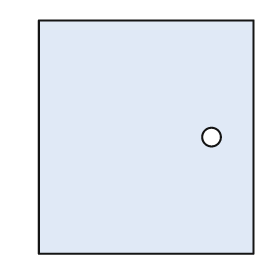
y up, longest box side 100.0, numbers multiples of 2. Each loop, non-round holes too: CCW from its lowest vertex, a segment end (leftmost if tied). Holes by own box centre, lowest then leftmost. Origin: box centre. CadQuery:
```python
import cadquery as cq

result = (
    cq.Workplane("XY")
    .moveTo(-46.0, -50.0)
    .lineTo(46.0, -50.0)
    .lineTo(46.0, 50.0)
    .lineTo(-46.0, 50.0)
    .close()
    .moveTo(28.0, 0.0)
    .circle(4.0)
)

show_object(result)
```